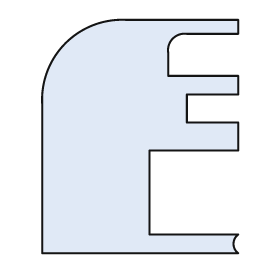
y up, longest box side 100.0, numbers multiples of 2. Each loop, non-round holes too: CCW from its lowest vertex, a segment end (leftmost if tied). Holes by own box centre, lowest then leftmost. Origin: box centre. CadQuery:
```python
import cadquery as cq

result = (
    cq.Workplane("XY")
    .moveTo(-42.0, -50.0)
    .lineTo(42.0, -50.0)
    .threePointArc((40.0, -46.0), (42.0, -42.0))
    .lineTo(4.0, -42.0)
    .lineTo(4.0, -6.0)
    .lineTo(42.0, -6.0)
    .lineTo(42.0, 6.0)
    .lineTo(20.0, 6.0)
    .lineTo(20.0, 18.0)
    .lineTo(42.0, 18.0)
    .lineTo(42.0, 26.0)
    .lineTo(12.0, 26.0)
    .lineTo(12.0, 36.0)
    .threePointArc((14.0, 42.0), (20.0, 44.0))
    .lineTo(42.0, 44.0)
    .lineTo(42.0, 50.0)
    .lineTo(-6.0, 50.0)
    .threePointArc((-32.0, 40.0), (-42.0, 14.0))
    .close()
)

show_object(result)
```